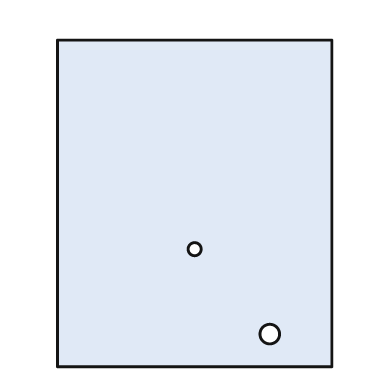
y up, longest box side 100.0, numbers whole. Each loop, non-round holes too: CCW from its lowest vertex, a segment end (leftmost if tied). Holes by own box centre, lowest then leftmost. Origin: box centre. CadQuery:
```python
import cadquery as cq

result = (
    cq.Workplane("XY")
    .moveTo(-42.0, -50.0)
    .lineTo(42.0, -50.0)
    .lineTo(42.0, 50.0)
    .lineTo(-42.0, 50.0)
    .close()
    .moveTo(23.0, -40.0)
    .circle(3.0)
    .moveTo(0.0, -14.0)
    .circle(2.0)
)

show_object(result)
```